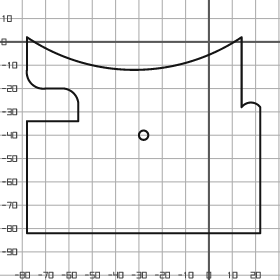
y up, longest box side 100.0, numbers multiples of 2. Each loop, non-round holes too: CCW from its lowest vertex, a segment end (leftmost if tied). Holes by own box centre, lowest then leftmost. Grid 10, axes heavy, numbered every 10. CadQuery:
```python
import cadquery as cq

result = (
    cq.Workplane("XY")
    .moveTo(-78.0, -82.0)
    .lineTo(22.0, -82.0)
    .lineTo(22.0, -28.0)
    .threePointArc((18.0, -26.0), (14.0, -28.0))
    .lineTo(14.0, 2.0)
    .threePointArc((-32.0, -12.0), (-78.0, 2.0))
    .lineTo(-78.0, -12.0)
    .threePointArc((-76.0, -18.0), (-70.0, -20.0))
    .lineTo(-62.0, -20.0)
    .threePointArc((-58.0, -22.0), (-56.0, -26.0))
    .lineTo(-56.0, -34.0)
    .lineTo(-78.0, -34.0)
    .close()
    .moveTo(-28.0, -40.0)
    .circle(2.0)
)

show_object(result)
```